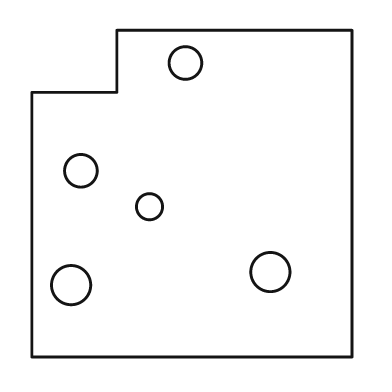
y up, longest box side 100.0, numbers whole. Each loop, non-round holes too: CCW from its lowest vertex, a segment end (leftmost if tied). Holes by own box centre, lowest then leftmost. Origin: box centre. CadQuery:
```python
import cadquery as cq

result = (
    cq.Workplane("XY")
    .moveTo(-49.0, -50.0)
    .lineTo(49.0, -50.0)
    .lineTo(49.0, 50.0)
    .lineTo(-23.0, 50.0)
    .lineTo(-23.0, 31.0)
    .lineTo(-49.0, 31.0)
    .close()
    .moveTo(-37.0, -28.0)
    .circle(6.0)
    .moveTo(24.0, -24.0)
    .circle(6.0)
    .moveTo(-13.0, -4.0)
    .circle(4.0)
    .moveTo(-34.0, 7.0)
    .circle(5.0)
    .moveTo(-2.0, 40.0)
    .circle(5.0)
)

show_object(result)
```